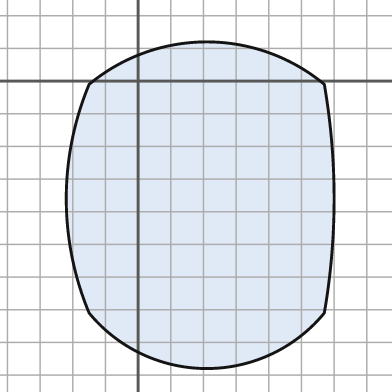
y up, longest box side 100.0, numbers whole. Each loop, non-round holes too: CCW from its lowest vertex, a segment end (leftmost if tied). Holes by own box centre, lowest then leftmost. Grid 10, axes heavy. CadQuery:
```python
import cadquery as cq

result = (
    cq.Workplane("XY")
    .moveTo(-15.0, -71.0)
    .threePointArc((21.0, -88.0), (57.0, -71.0))
    .threePointArc((60.0, -36.0), (57.0, -1.0))
    .threePointArc((21.0, 12.0), (-15.0, -1.0))
    .threePointArc((-22.0, -36.0), (-15.0, -71.0))
    .close()
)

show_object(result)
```